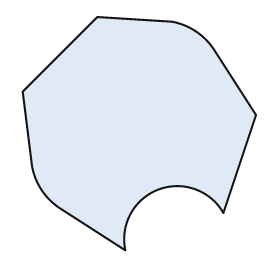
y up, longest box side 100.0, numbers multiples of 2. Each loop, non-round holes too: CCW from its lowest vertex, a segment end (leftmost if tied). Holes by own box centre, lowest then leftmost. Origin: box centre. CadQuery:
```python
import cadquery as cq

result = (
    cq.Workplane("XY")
    .moveTo(-6.0, -50.0)
    .threePointArc((8.0, -24.0), (36.0, -34.0))
    .lineTo(50.0, 8.0)
    .lineTo(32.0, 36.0)
    .threePointArc((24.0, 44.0), (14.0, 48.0))
    .lineTo(-18.0, 50.0)
    .lineTo(-50.0, 18.0)
    .lineTo(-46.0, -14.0)
    .threePointArc((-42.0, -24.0), (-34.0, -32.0))
    .close()
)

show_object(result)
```